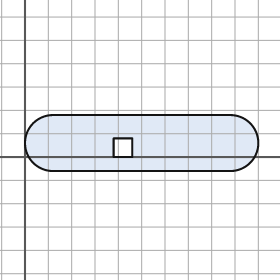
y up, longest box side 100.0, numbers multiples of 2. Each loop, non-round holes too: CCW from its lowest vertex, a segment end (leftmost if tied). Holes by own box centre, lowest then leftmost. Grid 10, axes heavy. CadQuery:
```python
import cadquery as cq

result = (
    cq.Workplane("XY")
    .moveTo(12.0, -6.0)
    .lineTo(88.0, -6.0)
    .threePointArc((100.0, 6.0), (88.0, 18.0))
    .lineTo(12.0, 18.0)
    .threePointArc((0.0, 6.0), (12.0, -6.0))
    .close()
    .moveTo(38.0, 0.0)
    .lineTo(46.0, 0.0)
    .lineTo(46.0, 8.0)
    .lineTo(38.0, 8.0)
    .close()
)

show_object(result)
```